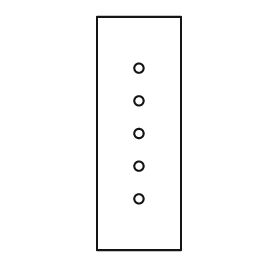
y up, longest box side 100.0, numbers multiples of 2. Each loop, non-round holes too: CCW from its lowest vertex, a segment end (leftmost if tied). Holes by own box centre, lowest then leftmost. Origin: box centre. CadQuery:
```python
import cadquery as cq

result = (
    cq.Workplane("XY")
    .moveTo(-18.0, -50.0)
    .lineTo(18.0, -50.0)
    .lineTo(18.0, 50.0)
    .lineTo(-18.0, 50.0)
    .close()
    .moveTo(0.0, -28.0)
    .circle(2.0)
    .moveTo(0.0, -14.0)
    .circle(2.0)
    .moveTo(0.0, 0.0)
    .circle(2.0)
    .moveTo(0.0, 14.0)
    .circle(2.0)
    .moveTo(0.0, 28.0)
    .circle(2.0)
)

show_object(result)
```